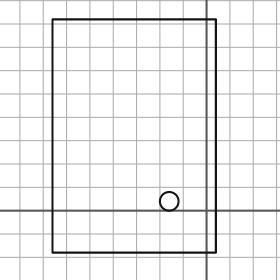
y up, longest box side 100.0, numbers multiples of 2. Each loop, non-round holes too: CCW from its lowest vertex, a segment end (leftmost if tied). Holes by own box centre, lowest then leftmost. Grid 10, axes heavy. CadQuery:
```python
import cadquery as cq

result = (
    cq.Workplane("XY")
    .moveTo(-66.0, -18.0)
    .lineTo(4.0, -18.0)
    .lineTo(4.0, 82.0)
    .lineTo(-66.0, 82.0)
    .close()
    .moveTo(-16.0, 4.0)
    .circle(4.0)
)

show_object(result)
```